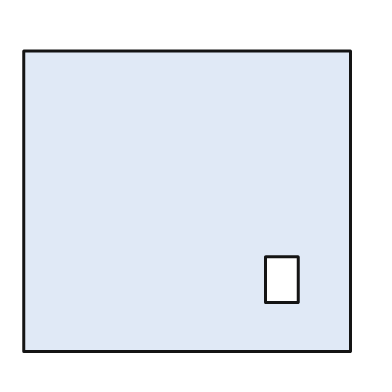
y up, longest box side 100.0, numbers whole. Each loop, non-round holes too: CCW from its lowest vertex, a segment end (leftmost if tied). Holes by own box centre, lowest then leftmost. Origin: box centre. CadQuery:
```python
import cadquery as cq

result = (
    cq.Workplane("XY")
    .moveTo(-50.0, -46.0)
    .lineTo(50.0, -46.0)
    .lineTo(50.0, 46.0)
    .lineTo(-50.0, 46.0)
    .close()
    .moveTo(24.0, -31.0)
    .lineTo(34.0, -31.0)
    .lineTo(34.0, -17.0)
    .lineTo(24.0, -17.0)
    .close()
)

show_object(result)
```